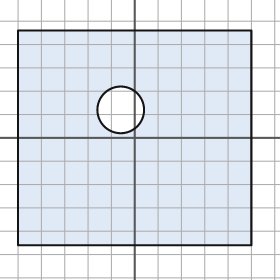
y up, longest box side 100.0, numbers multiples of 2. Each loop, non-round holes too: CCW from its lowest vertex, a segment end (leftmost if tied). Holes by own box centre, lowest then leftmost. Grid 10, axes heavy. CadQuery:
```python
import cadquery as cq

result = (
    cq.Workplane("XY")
    .moveTo(-50.0, -46.0)
    .lineTo(50.0, -46.0)
    .lineTo(50.0, 46.0)
    .lineTo(-50.0, 46.0)
    .close()
    .moveTo(-6.0, 12.0)
    .circle(10.0)
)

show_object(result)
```